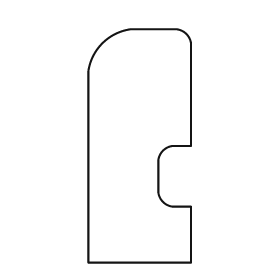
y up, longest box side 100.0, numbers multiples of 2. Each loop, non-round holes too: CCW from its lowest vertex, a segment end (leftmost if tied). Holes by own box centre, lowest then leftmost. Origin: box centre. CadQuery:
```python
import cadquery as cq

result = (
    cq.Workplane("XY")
    .moveTo(-22.0, -50.0)
    .lineTo(22.0, -50.0)
    .lineTo(22.0, -26.0)
    .lineTo(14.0, -26.0)
    .threePointArc((10.0, -24.0), (8.0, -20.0))
    .lineTo(8.0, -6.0)
    .threePointArc((10.0, -2.0), (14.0, 0.0))
    .lineTo(22.0, 0.0)
    .lineTo(22.0, 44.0)
    .threePointArc((20.0, 48.0), (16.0, 50.0))
    .lineTo(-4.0, 50.0)
    .threePointArc((-16.0, 44.0), (-22.0, 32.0))
    .close()
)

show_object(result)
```